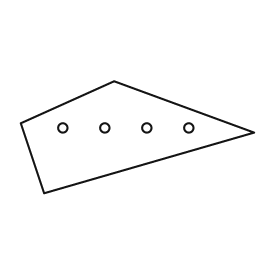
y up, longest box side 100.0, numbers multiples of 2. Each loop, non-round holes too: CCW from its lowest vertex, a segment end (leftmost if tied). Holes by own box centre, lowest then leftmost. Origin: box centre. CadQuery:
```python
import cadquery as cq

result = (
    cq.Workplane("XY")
    .moveTo(-40.0, -24.0)
    .lineTo(50.0, 2.0)
    .lineTo(-10.0, 24.0)
    .lineTo(-50.0, 6.0)
    .close()
    .moveTo(-32.0, 4.0)
    .circle(2.0)
    .moveTo(-14.0, 4.0)
    .circle(2.0)
    .moveTo(4.0, 4.0)
    .circle(2.0)
    .moveTo(22.0, 4.0)
    .circle(2.0)
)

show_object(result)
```